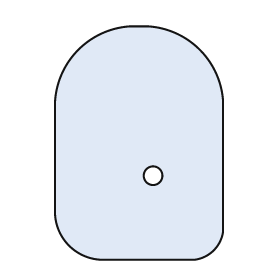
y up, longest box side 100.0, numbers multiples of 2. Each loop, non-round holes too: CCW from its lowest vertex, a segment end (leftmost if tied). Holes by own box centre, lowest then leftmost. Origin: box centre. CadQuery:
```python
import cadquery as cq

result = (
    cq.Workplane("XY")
    .moveTo(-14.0, -50.0)
    .lineTo(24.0, -50.0)
    .threePointArc((32.0, -46.0), (36.0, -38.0))
    .lineTo(36.0, 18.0)
    .threePointArc((26.0, 40.0), (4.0, 50.0))
    .lineTo(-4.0, 50.0)
    .threePointArc((-26.0, 40.0), (-36.0, 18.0))
    .lineTo(-36.0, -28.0)
    .threePointArc((-30.0, -44.0), (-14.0, -50.0))
    .close()
    .moveTo(6.0, -14.0)
    .circle(4.0)
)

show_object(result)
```